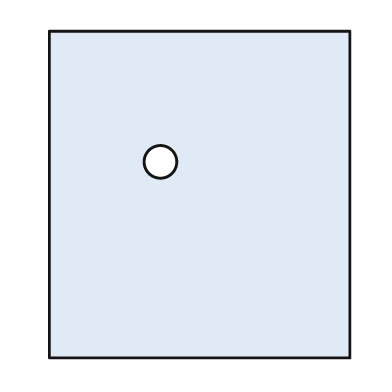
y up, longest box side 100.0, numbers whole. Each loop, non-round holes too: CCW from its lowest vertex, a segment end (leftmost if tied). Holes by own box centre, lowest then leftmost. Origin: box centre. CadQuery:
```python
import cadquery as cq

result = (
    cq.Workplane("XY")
    .moveTo(-46.0, -50.0)
    .lineTo(46.0, -50.0)
    .lineTo(46.0, 50.0)
    .lineTo(-46.0, 50.0)
    .close()
    .moveTo(-12.0, 10.0)
    .circle(5.0)
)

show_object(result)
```